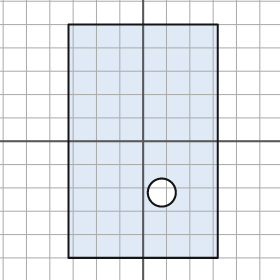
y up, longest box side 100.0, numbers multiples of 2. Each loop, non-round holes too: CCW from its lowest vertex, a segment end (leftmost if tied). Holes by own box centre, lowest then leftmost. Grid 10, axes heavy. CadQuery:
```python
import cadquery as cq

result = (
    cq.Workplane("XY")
    .moveTo(-32.0, -50.0)
    .lineTo(32.0, -50.0)
    .lineTo(32.0, 50.0)
    .lineTo(-32.0, 50.0)
    .close()
    .moveTo(8.0, -22.0)
    .circle(6.0)
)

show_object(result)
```